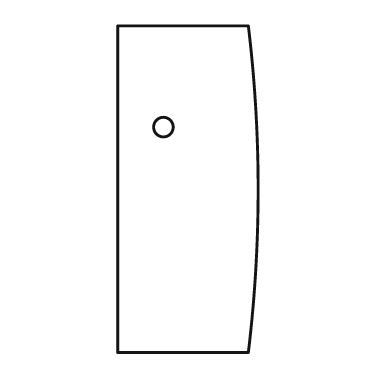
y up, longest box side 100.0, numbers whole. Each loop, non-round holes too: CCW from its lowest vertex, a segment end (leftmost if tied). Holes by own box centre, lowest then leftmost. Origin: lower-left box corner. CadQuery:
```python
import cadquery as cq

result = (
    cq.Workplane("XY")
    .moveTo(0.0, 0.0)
    .lineTo(40.0, 0.0)
    .threePointArc((43.0, 50.0), (40.0, 100.0))
    .lineTo(0.0, 100.0)
    .close()
    .moveTo(14.0, 69.0)
    .circle(3.0)
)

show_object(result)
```